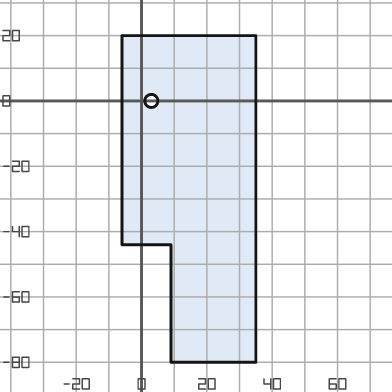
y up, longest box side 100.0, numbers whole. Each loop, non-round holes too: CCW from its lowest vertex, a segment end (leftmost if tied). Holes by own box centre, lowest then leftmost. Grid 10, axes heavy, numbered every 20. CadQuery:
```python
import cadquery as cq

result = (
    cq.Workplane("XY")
    .moveTo(9.0, -80.0)
    .lineTo(35.0, -80.0)
    .lineTo(35.0, 20.0)
    .lineTo(-6.0, 20.0)
    .lineTo(-6.0, -44.0)
    .lineTo(9.0, -44.0)
    .close()
    .moveTo(3.0, 0.0)
    .circle(2.0)
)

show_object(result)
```